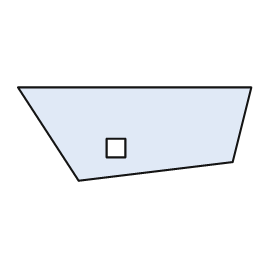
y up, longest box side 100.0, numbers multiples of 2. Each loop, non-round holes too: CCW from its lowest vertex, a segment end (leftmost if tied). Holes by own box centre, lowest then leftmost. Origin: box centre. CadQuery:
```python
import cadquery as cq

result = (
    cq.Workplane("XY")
    .moveTo(-24.0, -20.0)
    .lineTo(42.0, -12.0)
    .lineTo(50.0, 20.0)
    .lineTo(-50.0, 20.0)
    .close()
    .moveTo(-12.0, -10.0)
    .lineTo(-4.0, -10.0)
    .lineTo(-4.0, -2.0)
    .lineTo(-12.0, -2.0)
    .close()
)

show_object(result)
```